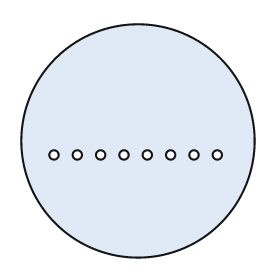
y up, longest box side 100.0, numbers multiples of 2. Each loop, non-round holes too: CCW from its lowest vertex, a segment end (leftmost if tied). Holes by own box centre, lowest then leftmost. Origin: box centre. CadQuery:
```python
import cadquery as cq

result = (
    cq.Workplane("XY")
    .moveTo(0.0, 0.0)
    .circle(50.0)
    .moveTo(-36.0, -6.0)
    .circle(2.0)
    .moveTo(-26.0, -6.0)
    .circle(2.0)
    .moveTo(-16.0, -6.0)
    .circle(2.0)
    .moveTo(-6.0, -6.0)
    .circle(2.0)
    .moveTo(4.0, -6.0)
    .circle(2.0)
    .moveTo(14.0, -6.0)
    .circle(2.0)
    .moveTo(24.0, -6.0)
    .circle(2.0)
    .moveTo(34.0, -6.0)
    .circle(2.0)
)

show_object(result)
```